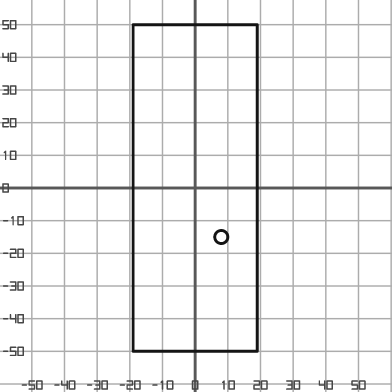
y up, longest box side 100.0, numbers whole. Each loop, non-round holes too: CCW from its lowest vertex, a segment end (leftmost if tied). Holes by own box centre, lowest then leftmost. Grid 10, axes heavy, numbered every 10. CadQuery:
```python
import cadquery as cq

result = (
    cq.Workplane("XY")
    .moveTo(-19.0, -50.0)
    .lineTo(19.0, -50.0)
    .lineTo(19.0, 50.0)
    .lineTo(-19.0, 50.0)
    .close()
    .moveTo(8.0, -15.0)
    .circle(2.0)
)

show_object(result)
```